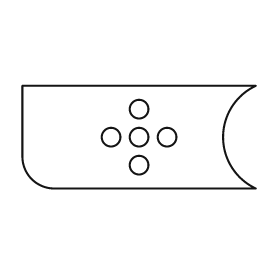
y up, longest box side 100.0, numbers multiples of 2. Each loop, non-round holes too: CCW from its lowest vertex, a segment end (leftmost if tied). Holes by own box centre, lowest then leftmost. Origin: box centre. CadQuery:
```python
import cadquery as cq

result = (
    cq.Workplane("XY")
    .moveTo(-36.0, -22.0)
    .lineTo(50.0, -22.0)
    .threePointArc((36.0, 0.0), (50.0, 22.0))
    .lineTo(-50.0, 22.0)
    .lineTo(-50.0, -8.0)
    .threePointArc((-46.0, -18.0), (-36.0, -22.0))
    .close()
    .moveTo(0.0, -12.0)
    .circle(4.0)
    .moveTo(-12.0, 0.0)
    .circle(4.0)
    .moveTo(0.0, 0.0)
    .circle(4.0)
    .moveTo(12.0, 0.0)
    .circle(4.0)
    .moveTo(0.0, 12.0)
    .circle(4.0)
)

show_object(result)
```